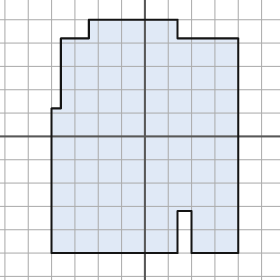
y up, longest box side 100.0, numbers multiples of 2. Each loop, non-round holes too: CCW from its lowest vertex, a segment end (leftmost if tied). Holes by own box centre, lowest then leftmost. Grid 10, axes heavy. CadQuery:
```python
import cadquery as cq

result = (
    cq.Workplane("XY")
    .moveTo(-40.0, -50.0)
    .lineTo(14.0, -50.0)
    .lineTo(14.0, -32.0)
    .lineTo(20.0, -32.0)
    .lineTo(20.0, -50.0)
    .lineTo(40.0, -50.0)
    .lineTo(40.0, 42.0)
    .lineTo(14.0, 42.0)
    .lineTo(14.0, 50.0)
    .lineTo(-24.0, 50.0)
    .lineTo(-24.0, 42.0)
    .lineTo(-36.0, 42.0)
    .lineTo(-36.0, 12.0)
    .lineTo(-40.0, 12.0)
    .close()
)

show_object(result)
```